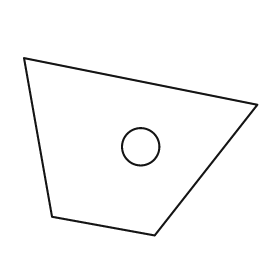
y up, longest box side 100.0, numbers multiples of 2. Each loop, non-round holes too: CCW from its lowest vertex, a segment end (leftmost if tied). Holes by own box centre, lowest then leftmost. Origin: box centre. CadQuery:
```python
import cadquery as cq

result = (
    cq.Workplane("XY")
    .moveTo(6.0, -38.0)
    .lineTo(50.0, 18.0)
    .lineTo(-50.0, 38.0)
    .lineTo(-38.0, -30.0)
    .close()
    .moveTo(0.0, 0.0)
    .circle(8.0)
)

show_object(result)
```